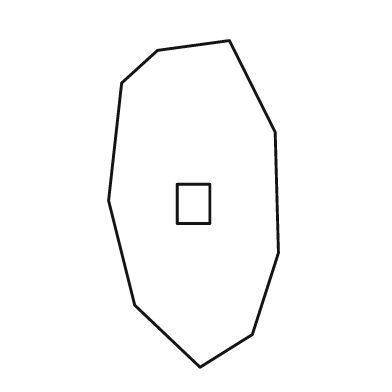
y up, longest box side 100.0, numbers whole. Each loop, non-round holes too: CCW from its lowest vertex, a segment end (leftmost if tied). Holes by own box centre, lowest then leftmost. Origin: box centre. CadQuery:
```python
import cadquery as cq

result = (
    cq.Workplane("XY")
    .moveTo(2.0, -50.0)
    .lineTo(18.0, -40.0)
    .lineTo(26.0, -15.0)
    .lineTo(25.0, 22.0)
    .lineTo(11.0, 50.0)
    .lineTo(-11.0, 47.0)
    .lineTo(-22.0, 37.0)
    .lineTo(-26.0, 1.0)
    .lineTo(-18.0, -31.0)
    .close()
    .moveTo(-5.0, -6.0)
    .lineTo(5.0, -6.0)
    .lineTo(5.0, 6.0)
    .lineTo(-5.0, 6.0)
    .close()
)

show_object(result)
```